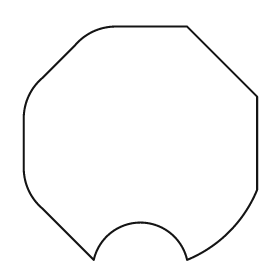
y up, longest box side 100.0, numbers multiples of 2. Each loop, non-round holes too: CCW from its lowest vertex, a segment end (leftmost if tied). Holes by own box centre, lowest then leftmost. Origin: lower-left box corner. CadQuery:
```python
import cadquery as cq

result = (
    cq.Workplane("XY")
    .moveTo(30.0, 0.0)
    .threePointArc((50.0, 16.0), (70.0, 0.0))
    .threePointArc((88.0, 12.0), (100.0, 30.0))
    .lineTo(100.0, 70.0)
    .lineTo(70.0, 100.0)
    .lineTo(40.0, 100.0)
    .threePointArc((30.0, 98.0), (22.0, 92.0))
    .lineTo(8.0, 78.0)
    .threePointArc((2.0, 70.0), (0.0, 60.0))
    .lineTo(0.0, 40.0)
    .threePointArc((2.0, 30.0), (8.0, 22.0))
    .close()
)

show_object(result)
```